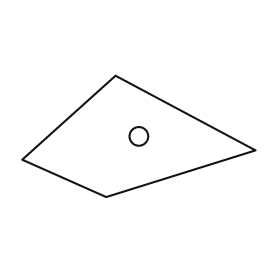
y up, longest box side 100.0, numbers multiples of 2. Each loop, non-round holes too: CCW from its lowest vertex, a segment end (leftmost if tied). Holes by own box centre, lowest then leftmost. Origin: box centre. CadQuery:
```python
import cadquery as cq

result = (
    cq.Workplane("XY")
    .moveTo(-14.0, -26.0)
    .lineTo(50.0, -6.0)
    .lineTo(-10.0, 26.0)
    .lineTo(-50.0, -10.0)
    .close()
    .moveTo(0.0, 0.0)
    .circle(4.0)
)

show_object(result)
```